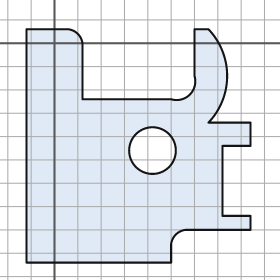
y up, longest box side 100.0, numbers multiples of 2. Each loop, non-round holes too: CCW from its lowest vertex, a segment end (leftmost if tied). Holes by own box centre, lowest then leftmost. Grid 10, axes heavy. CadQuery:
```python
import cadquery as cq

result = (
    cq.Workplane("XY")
    .moveTo(-12.0, -94.0)
    .lineTo(50.0, -94.0)
    .lineTo(50.0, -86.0)
    .threePointArc((52.0, -82.0), (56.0, -80.0))
    .lineTo(84.0, -80.0)
    .lineTo(84.0, -74.0)
    .lineTo(72.0, -74.0)
    .lineTo(72.0, -44.0)
    .lineTo(84.0, -44.0)
    .lineTo(84.0, -34.0)
    .lineTo(66.0, -34.0)
    .threePointArc((74.0, -14.0), (66.0, 6.0))
    .lineTo(60.0, 6.0)
    .lineTo(60.0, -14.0)
    .threePointArc((58.0, -22.0), (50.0, -24.0))
    .lineTo(12.0, -24.0)
    .lineTo(12.0, 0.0)
    .threePointArc((10.0, 4.0), (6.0, 6.0))
    .lineTo(-12.0, 6.0)
    .close()
    .moveTo(42.0, -46.0)
    .circle(10.0)
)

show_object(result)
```